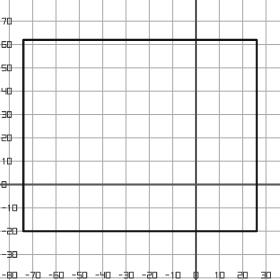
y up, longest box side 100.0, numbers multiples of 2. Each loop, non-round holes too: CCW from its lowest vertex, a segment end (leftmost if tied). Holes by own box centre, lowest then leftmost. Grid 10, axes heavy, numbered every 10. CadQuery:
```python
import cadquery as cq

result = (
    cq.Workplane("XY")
    .moveTo(-74.0, -20.0)
    .lineTo(26.0, -20.0)
    .lineTo(26.0, 62.0)
    .lineTo(-74.0, 62.0)
    .close()
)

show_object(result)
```